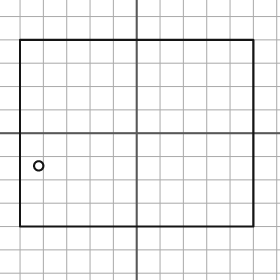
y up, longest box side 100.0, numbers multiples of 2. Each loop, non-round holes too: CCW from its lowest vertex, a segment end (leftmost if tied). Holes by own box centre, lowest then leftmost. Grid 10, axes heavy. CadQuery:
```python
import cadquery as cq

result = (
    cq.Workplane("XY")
    .moveTo(-50.0, -40.0)
    .lineTo(50.0, -40.0)
    .lineTo(50.0, 40.0)
    .lineTo(-50.0, 40.0)
    .close()
    .moveTo(-42.0, -14.0)
    .circle(2.0)
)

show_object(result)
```